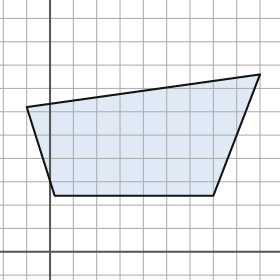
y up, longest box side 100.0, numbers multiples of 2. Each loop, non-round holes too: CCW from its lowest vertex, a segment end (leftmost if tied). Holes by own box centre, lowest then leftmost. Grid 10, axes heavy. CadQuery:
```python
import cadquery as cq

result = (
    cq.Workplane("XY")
    .moveTo(2.0, 24.0)
    .lineTo(70.0, 24.0)
    .lineTo(90.0, 76.0)
    .lineTo(-10.0, 62.0)
    .close()
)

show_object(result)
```